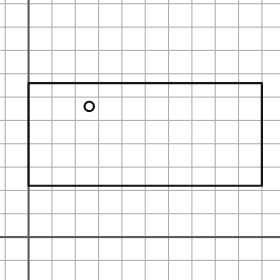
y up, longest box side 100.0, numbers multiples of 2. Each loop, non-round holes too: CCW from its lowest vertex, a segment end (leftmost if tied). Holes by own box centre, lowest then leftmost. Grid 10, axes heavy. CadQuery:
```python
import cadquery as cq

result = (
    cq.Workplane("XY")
    .moveTo(0.0, 22.0)
    .lineTo(100.0, 22.0)
    .lineTo(100.0, 66.0)
    .lineTo(0.0, 66.0)
    .close()
    .moveTo(26.0, 56.0)
    .circle(2.0)
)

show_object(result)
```